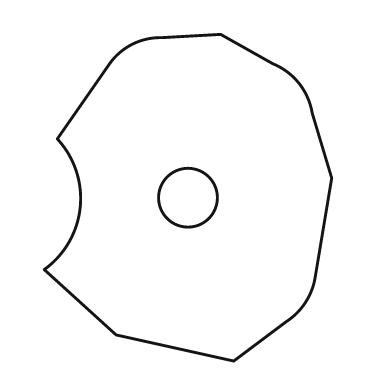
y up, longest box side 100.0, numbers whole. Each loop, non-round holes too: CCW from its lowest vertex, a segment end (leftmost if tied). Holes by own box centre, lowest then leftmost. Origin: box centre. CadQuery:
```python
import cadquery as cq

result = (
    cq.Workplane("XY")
    .moveTo(14.0, -50.0)
    .lineTo(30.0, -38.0)
    .threePointArc((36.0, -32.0), (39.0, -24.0))
    .lineTo(44.0, 6.0)
    .lineTo(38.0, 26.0)
    .threePointArc((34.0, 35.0), (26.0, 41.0))
    .lineTo(10.0, 50.0)
    .lineTo(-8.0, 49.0)
    .threePointArc((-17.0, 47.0), (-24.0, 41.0))
    .lineTo(-40.0, 18.0)
    .threePointArc((-33.0, -3.0), (-44.0, -22.0))
    .lineTo(-22.0, -42.0)
    .close()
    .moveTo(0.0, 0.0)
    .circle(9.0)
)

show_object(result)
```